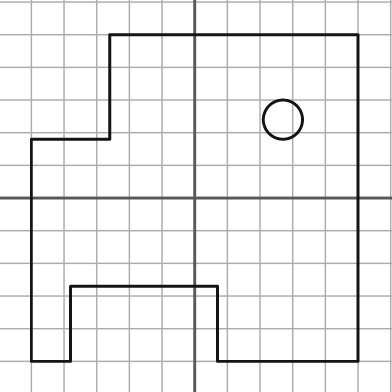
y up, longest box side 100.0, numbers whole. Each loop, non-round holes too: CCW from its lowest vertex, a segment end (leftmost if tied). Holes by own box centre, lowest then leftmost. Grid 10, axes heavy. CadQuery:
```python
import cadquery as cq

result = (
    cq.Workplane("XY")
    .moveTo(-50.0, -50.0)
    .lineTo(-38.0, -50.0)
    .lineTo(-38.0, -27.0)
    .lineTo(7.0, -27.0)
    .lineTo(7.0, -50.0)
    .lineTo(50.0, -50.0)
    .lineTo(50.0, 50.0)
    .lineTo(-26.0, 50.0)
    .lineTo(-26.0, 18.0)
    .lineTo(-50.0, 18.0)
    .close()
    .moveTo(27.0, 24.0)
    .circle(6.0)
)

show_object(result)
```